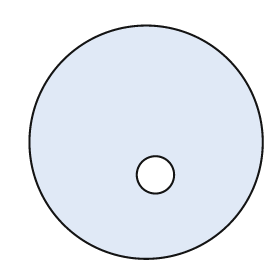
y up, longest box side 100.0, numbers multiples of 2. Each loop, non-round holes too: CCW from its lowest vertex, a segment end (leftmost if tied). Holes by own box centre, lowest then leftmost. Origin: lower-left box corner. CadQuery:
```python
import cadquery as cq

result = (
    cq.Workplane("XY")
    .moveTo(50.0, 50.0)
    .circle(50.0)
    .moveTo(54.0, 36.0)
    .circle(8.0)
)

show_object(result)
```